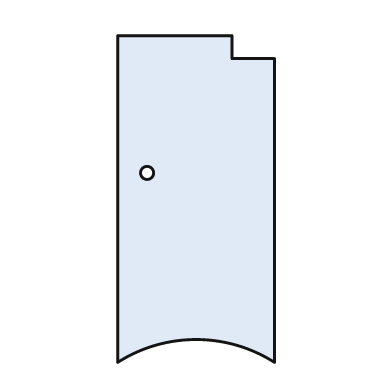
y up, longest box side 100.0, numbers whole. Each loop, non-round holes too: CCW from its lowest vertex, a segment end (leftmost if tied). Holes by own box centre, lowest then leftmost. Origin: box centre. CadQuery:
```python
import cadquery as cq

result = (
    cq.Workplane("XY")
    .moveTo(-24.0, -50.0)
    .threePointArc((0.0, -43.0), (24.0, -50.0))
    .lineTo(24.0, 43.0)
    .lineTo(11.0, 43.0)
    .lineTo(11.0, 50.0)
    .lineTo(-24.0, 50.0)
    .close()
    .moveTo(-15.0, 8.0)
    .circle(2.0)
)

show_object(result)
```